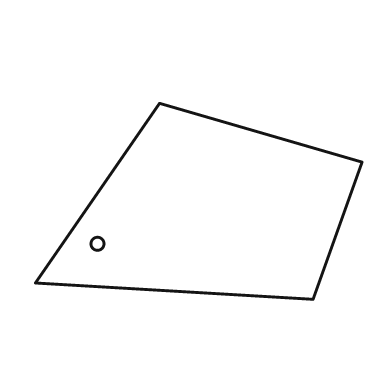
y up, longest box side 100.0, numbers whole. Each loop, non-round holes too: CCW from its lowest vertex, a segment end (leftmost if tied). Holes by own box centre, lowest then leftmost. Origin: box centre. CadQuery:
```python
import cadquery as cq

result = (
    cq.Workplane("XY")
    .moveTo(35.0, -30.0)
    .lineTo(50.0, 12.0)
    .lineTo(-12.0, 30.0)
    .lineTo(-50.0, -25.0)
    .close()
    .moveTo(-31.0, -13.0)
    .circle(2.0)
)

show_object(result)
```